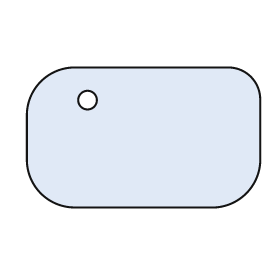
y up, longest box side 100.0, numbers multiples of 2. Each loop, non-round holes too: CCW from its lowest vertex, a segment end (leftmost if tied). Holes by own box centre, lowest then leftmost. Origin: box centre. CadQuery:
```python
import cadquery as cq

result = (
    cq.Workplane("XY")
    .moveTo(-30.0, -30.0)
    .lineTo(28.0, -30.0)
    .threePointArc((44.0, -24.0), (50.0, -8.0))
    .lineTo(50.0, 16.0)
    .threePointArc((46.0, 26.0), (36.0, 30.0))
    .lineTo(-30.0, 30.0)
    .threePointArc((-44.0, 24.0), (-50.0, 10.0))
    .lineTo(-50.0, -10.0)
    .threePointArc((-44.0, -24.0), (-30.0, -30.0))
    .close()
    .moveTo(-24.0, 16.0)
    .circle(4.0)
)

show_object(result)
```